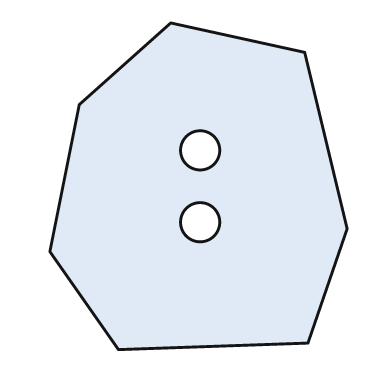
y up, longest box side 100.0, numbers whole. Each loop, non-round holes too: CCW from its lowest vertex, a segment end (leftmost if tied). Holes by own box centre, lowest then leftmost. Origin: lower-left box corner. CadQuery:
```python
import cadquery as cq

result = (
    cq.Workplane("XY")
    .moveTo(21.0, 0.0)
    .lineTo(79.0, 2.0)
    .lineTo(91.0, 37.0)
    .lineTo(78.0, 91.0)
    .lineTo(37.0, 100.0)
    .lineTo(9.0, 75.0)
    .lineTo(0.0, 30.0)
    .close()
    .moveTo(46.0, 39.0)
    .circle(6.0)
    .moveTo(46.0, 61.0)
    .circle(6.0)
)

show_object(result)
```